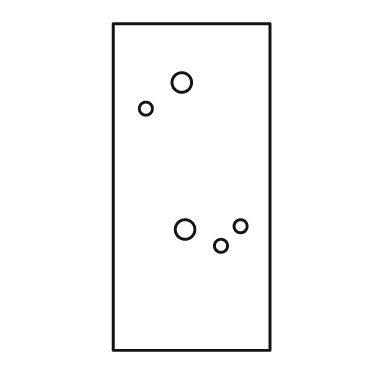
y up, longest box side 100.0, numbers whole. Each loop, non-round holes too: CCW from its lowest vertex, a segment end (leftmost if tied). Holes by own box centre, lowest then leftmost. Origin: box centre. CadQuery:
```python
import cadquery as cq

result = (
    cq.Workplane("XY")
    .moveTo(-24.0, -50.0)
    .lineTo(24.0, -50.0)
    .lineTo(24.0, 50.0)
    .lineTo(-24.0, 50.0)
    .close()
    .moveTo(9.0, -18.0)
    .circle(2.0)
    .moveTo(-2.0, -13.0)
    .circle(3.0)
    .moveTo(15.0, -12.0)
    .circle(2.0)
    .moveTo(-14.0, 24.0)
    .circle(2.0)
    .moveTo(-3.0, 32.0)
    .circle(3.0)
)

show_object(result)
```